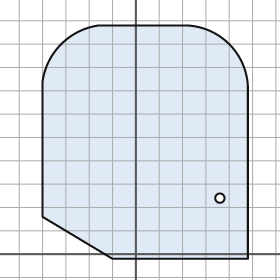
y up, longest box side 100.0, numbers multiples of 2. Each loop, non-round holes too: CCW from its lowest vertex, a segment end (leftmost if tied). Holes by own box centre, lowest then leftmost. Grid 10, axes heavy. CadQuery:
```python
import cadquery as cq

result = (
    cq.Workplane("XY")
    .moveTo(-10.0, -2.0)
    .lineTo(48.0, -2.0)
    .lineTo(48.0, 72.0)
    .threePointArc((40.0, 90.0), (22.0, 98.0))
    .lineTo(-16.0, 98.0)
    .threePointArc((-32.0, 90.0), (-40.0, 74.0))
    .lineTo(-40.0, 16.0)
    .close()
    .moveTo(36.0, 24.0)
    .circle(2.0)
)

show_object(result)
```